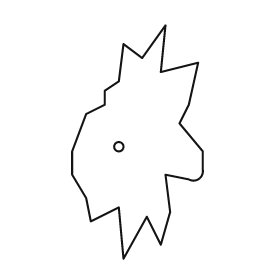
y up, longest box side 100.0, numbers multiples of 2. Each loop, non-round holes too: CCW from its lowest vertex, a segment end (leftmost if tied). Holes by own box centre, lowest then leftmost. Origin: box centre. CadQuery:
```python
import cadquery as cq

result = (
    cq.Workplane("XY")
    .moveTo(-6.0, -50.0)
    .lineTo(4.0, -32.0)
    .lineTo(10.0, -44.0)
    .lineTo(14.0, -30.0)
    .lineTo(12.0, -14.0)
    .lineTo(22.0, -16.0)
    .threePointArc((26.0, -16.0), (28.0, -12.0))
    .lineTo(28.0, -4.0)
    .lineTo(18.0, 8.0)
    .lineTo(22.0, 16.0)
    .lineTo(26.0, 34.0)
    .lineTo(10.0, 30.0)
    .lineTo(12.0, 50.0)
    .lineTo(2.0, 36.0)
    .lineTo(-6.0, 42.0)
    .lineTo(-8.0, 26.0)
    .lineTo(-14.0, 22.0)
    .lineTo(-14.0, 16.0)
    .lineTo(-22.0, 12.0)
    .lineTo(-28.0, -4.0)
    .lineTo(-28.0, -14.0)
    .lineTo(-22.0, -24.0)
    .lineTo(-20.0, -34.0)
    .lineTo(-8.0, -28.0)
    .close()
    .moveTo(-8.0, -2.0)
    .circle(2.0)
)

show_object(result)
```